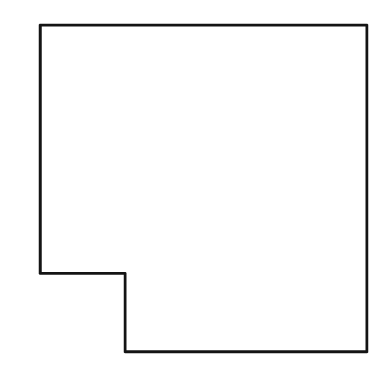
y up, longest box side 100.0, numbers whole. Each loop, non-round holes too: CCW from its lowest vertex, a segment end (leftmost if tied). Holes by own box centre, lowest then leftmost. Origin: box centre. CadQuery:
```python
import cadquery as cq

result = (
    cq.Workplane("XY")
    .moveTo(-24.0, -50.0)
    .lineTo(50.0, -50.0)
    .lineTo(50.0, 50.0)
    .lineTo(-50.0, 50.0)
    .lineTo(-50.0, -26.0)
    .lineTo(-24.0, -26.0)
    .close()
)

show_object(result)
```